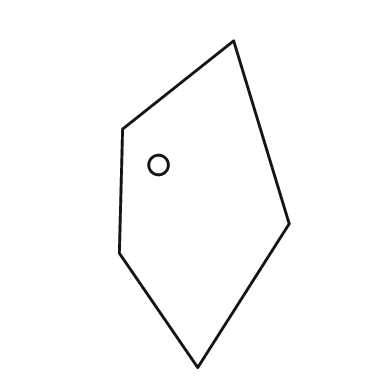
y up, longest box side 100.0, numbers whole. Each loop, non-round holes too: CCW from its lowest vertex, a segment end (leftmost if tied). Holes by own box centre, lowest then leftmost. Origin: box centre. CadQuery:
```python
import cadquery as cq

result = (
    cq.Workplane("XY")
    .moveTo(-2.0, -50.0)
    .lineTo(26.0, -6.0)
    .lineTo(9.0, 50.0)
    .lineTo(-25.0, 23.0)
    .lineTo(-26.0, -15.0)
    .close()
    .moveTo(-14.0, 12.0)
    .circle(3.0)
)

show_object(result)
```